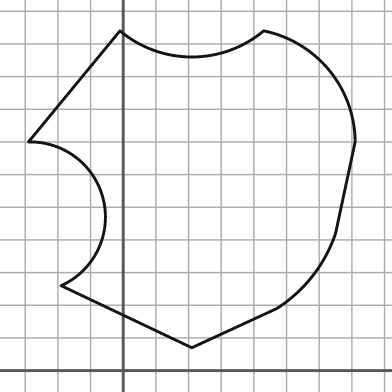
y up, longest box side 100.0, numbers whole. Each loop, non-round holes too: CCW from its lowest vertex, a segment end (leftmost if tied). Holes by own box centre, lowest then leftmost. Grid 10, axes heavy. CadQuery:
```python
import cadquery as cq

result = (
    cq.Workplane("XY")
    .moveTo(21.0, 7.0)
    .lineTo(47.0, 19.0)
    .threePointArc((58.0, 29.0), (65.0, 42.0))
    .lineTo(71.0, 70.0)
    .threePointArc((63.0, 92.0), (43.0, 104.0))
    .threePointArc((21.0, 96.0), (-1.0, 104.0))
    .lineTo(-29.0, 70.0)
    .threePointArc((-6.0, 52.0), (-19.0, 26.0))
    .close()
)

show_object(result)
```